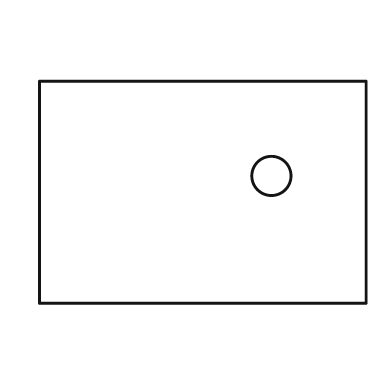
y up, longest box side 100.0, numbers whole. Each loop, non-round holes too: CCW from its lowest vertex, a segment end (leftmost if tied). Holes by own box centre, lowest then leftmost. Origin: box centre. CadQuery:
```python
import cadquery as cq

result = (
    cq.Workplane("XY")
    .moveTo(-50.0, -34.0)
    .lineTo(50.0, -34.0)
    .lineTo(50.0, 34.0)
    .lineTo(-50.0, 34.0)
    .close()
    .moveTo(21.0, 5.0)
    .circle(6.0)
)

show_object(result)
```